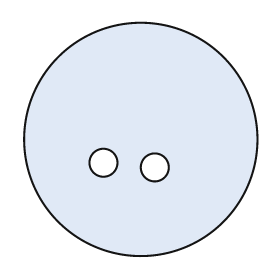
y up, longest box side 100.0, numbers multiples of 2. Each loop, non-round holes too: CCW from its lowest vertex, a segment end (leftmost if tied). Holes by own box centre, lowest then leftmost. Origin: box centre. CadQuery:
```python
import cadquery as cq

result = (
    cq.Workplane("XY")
    .moveTo(0.0, 0.0)
    .circle(50.0)
    .moveTo(6.0, -12.0)
    .circle(6.0)
    .moveTo(-16.0, -10.0)
    .circle(6.0)
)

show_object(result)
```